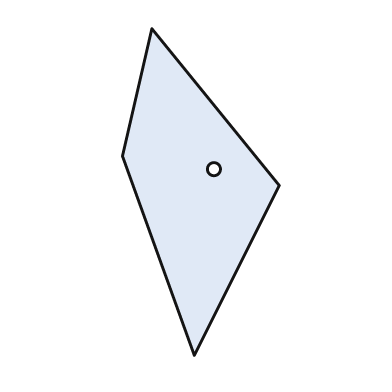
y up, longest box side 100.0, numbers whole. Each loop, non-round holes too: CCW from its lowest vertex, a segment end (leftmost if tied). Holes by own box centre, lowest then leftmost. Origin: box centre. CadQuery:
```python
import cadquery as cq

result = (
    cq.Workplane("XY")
    .moveTo(-2.0, -50.0)
    .lineTo(24.0, 2.0)
    .lineTo(-15.0, 50.0)
    .lineTo(-24.0, 11.0)
    .close()
    .moveTo(4.0, 7.0)
    .circle(2.0)
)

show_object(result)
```